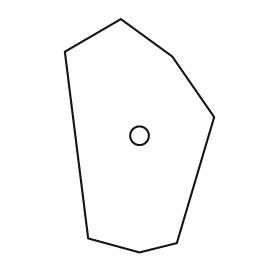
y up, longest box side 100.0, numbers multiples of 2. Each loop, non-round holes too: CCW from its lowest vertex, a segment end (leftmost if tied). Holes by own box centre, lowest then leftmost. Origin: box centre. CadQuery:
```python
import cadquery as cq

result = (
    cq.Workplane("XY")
    .moveTo(0.0, -50.0)
    .lineTo(16.0, -46.0)
    .lineTo(32.0, 8.0)
    .lineTo(14.0, 34.0)
    .lineTo(-8.0, 50.0)
    .lineTo(-32.0, 36.0)
    .lineTo(-22.0, -44.0)
    .close()
    .moveTo(0.0, 0.0)
    .circle(4.0)
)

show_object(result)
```